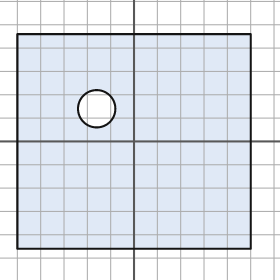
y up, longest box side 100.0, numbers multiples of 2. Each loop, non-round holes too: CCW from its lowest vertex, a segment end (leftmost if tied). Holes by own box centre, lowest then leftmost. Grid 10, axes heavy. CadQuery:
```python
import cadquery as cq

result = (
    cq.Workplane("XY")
    .moveTo(-50.0, -46.0)
    .lineTo(50.0, -46.0)
    .lineTo(50.0, 46.0)
    .lineTo(-50.0, 46.0)
    .close()
    .moveTo(-16.0, 14.0)
    .circle(8.0)
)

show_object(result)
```